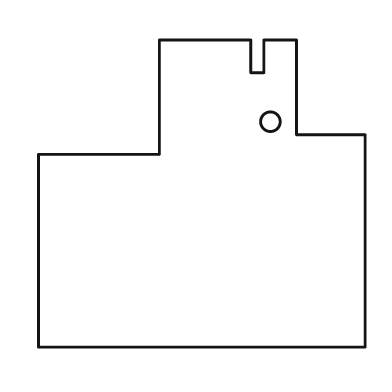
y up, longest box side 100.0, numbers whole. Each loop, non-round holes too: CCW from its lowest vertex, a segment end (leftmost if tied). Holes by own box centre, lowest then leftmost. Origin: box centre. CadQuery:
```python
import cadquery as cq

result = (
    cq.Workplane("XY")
    .moveTo(-50.0, -47.0)
    .lineTo(50.0, -47.0)
    .lineTo(50.0, 18.0)
    .lineTo(29.0, 18.0)
    .lineTo(29.0, 47.0)
    .lineTo(19.0, 47.0)
    .lineTo(19.0, 37.0)
    .lineTo(15.0, 37.0)
    .lineTo(15.0, 47.0)
    .lineTo(-13.0, 47.0)
    .lineTo(-13.0, 12.0)
    .lineTo(-50.0, 12.0)
    .close()
    .moveTo(21.0, 22.0)
    .circle(3.0)
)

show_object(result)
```